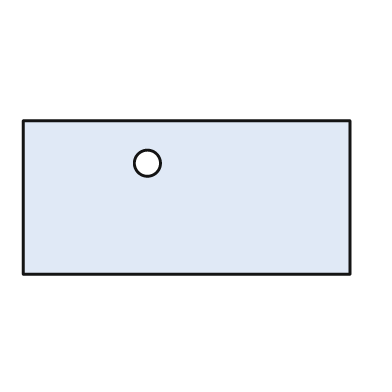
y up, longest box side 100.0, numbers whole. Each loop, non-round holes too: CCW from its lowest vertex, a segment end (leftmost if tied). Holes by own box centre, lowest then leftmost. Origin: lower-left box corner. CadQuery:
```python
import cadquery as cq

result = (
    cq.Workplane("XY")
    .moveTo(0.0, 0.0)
    .lineTo(100.0, 0.0)
    .lineTo(100.0, 47.0)
    .lineTo(0.0, 47.0)
    .close()
    .moveTo(38.0, 34.0)
    .circle(4.0)
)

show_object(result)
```